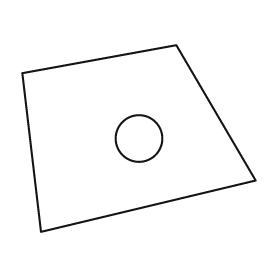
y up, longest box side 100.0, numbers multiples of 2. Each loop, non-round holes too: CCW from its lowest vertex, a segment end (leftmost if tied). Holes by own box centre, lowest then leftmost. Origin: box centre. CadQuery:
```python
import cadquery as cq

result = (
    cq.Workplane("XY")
    .moveTo(-42.0, -40.0)
    .lineTo(50.0, -18.0)
    .lineTo(16.0, 40.0)
    .lineTo(-50.0, 28.0)
    .close()
    .moveTo(0.0, 0.0)
    .circle(10.0)
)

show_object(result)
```